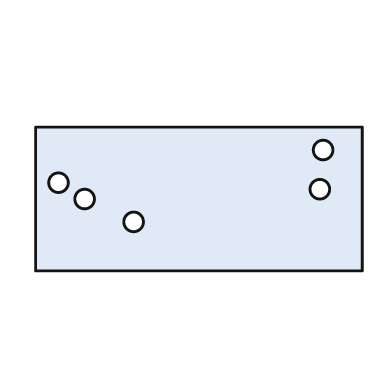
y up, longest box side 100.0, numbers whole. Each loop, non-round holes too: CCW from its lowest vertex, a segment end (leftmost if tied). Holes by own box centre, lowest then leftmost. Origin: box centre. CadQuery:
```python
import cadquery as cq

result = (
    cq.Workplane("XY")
    .moveTo(-50.0, -22.0)
    .lineTo(50.0, -22.0)
    .lineTo(50.0, 22.0)
    .lineTo(-50.0, 22.0)
    .close()
    .moveTo(-20.0, -7.0)
    .circle(3.0)
    .moveTo(-35.0, 0.0)
    .circle(3.0)
    .moveTo(37.0, 3.0)
    .circle(3.0)
    .moveTo(-43.0, 5.0)
    .circle(3.0)
    .moveTo(38.0, 15.0)
    .circle(3.0)
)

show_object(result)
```